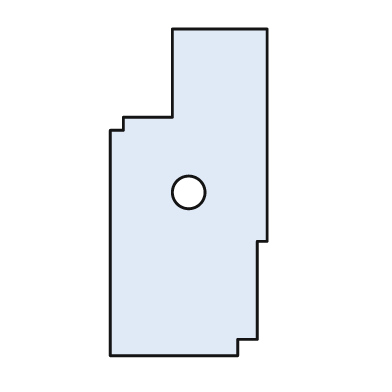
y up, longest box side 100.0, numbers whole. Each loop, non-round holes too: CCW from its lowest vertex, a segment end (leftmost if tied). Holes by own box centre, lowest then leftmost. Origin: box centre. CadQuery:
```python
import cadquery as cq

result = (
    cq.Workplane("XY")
    .moveTo(-24.0, -50.0)
    .lineTo(15.0, -50.0)
    .lineTo(15.0, -45.0)
    .lineTo(21.0, -45.0)
    .lineTo(21.0, -15.0)
    .lineTo(24.0, -15.0)
    .lineTo(24.0, 50.0)
    .lineTo(-5.0, 50.0)
    .lineTo(-5.0, 23.0)
    .lineTo(-20.0, 23.0)
    .lineTo(-20.0, 19.0)
    .lineTo(-24.0, 19.0)
    .close()
    .moveTo(0.0, 0.0)
    .circle(5.0)
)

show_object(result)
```